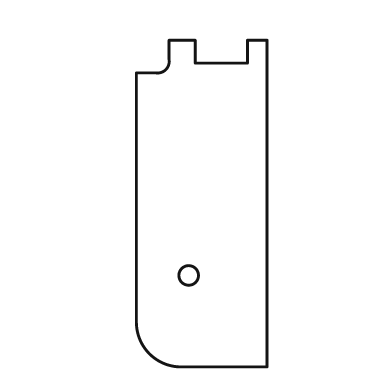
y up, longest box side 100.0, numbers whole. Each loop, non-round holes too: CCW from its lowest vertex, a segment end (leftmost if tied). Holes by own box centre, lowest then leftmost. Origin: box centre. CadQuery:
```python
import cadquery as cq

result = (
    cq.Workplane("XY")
    .moveTo(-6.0, -50.0)
    .lineTo(20.0, -50.0)
    .lineTo(20.0, 50.0)
    .lineTo(14.0, 50.0)
    .lineTo(14.0, 43.0)
    .lineTo(-2.0, 43.0)
    .lineTo(-2.0, 50.0)
    .lineTo(-10.0, 50.0)
    .lineTo(-10.0, 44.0)
    .threePointArc((-11.0, 41.0), (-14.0, 40.0))
    .lineTo(-20.0, 40.0)
    .lineTo(-20.0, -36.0)
    .threePointArc((-16.0, -46.0), (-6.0, -50.0))
    .close()
    .moveTo(-4.0, -22.0)
    .circle(3.0)
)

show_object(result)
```